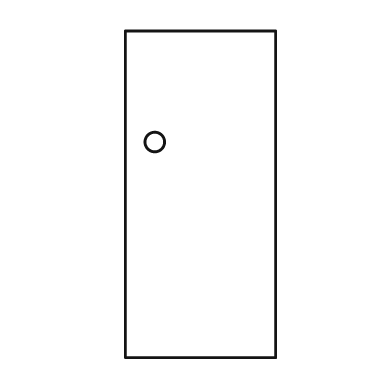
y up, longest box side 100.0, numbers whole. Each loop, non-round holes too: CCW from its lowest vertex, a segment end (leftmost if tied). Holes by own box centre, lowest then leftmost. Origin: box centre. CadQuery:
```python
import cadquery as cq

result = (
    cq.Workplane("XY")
    .moveTo(-23.0, -50.0)
    .lineTo(23.0, -50.0)
    .lineTo(23.0, 50.0)
    .lineTo(-23.0, 50.0)
    .close()
    .moveTo(-14.0, 16.0)
    .circle(3.0)
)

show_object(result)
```